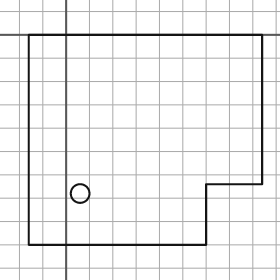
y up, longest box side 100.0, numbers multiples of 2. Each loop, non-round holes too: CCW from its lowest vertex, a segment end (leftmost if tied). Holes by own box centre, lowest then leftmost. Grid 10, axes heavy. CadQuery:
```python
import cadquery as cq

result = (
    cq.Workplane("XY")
    .moveTo(-16.0, -90.0)
    .lineTo(60.0, -90.0)
    .lineTo(60.0, -64.0)
    .lineTo(84.0, -64.0)
    .lineTo(84.0, 0.0)
    .lineTo(-16.0, 0.0)
    .close()
    .moveTo(6.0, -68.0)
    .circle(4.0)
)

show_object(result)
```